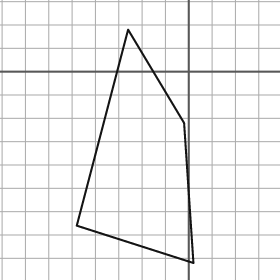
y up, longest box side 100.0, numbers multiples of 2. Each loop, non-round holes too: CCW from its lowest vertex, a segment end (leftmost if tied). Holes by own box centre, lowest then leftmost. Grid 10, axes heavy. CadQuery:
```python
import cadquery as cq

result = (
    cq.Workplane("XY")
    .moveTo(2.0, -82.0)
    .lineTo(-2.0, -22.0)
    .lineTo(-26.0, 18.0)
    .lineTo(-48.0, -66.0)
    .close()
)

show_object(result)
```